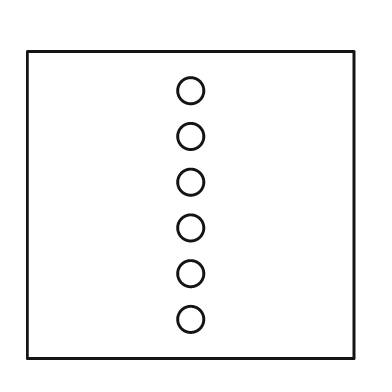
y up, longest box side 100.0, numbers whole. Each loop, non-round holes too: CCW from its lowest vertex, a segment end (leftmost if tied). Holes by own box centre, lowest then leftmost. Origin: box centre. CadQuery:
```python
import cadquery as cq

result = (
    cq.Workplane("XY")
    .moveTo(-50.0, -47.0)
    .lineTo(50.0, -47.0)
    .lineTo(50.0, 47.0)
    .lineTo(-50.0, 47.0)
    .close()
    .moveTo(0.0, -35.0)
    .circle(4.0)
    .moveTo(0.0, -21.0)
    .circle(4.0)
    .moveTo(0.0, -7.0)
    .circle(4.0)
    .moveTo(0.0, 7.0)
    .circle(4.0)
    .moveTo(0.0, 21.0)
    .circle(4.0)
    .moveTo(0.0, 35.0)
    .circle(4.0)
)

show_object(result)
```